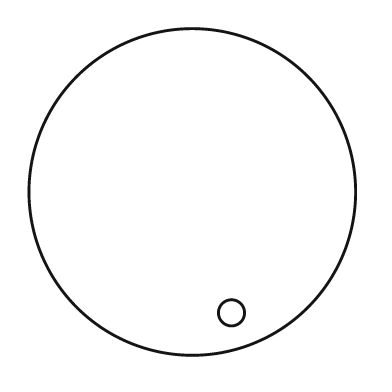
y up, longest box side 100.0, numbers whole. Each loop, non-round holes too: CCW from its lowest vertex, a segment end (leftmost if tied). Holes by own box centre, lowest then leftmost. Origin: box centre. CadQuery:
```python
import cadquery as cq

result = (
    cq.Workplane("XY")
    .moveTo(0.0, 0.0)
    .circle(50.0)
    .moveTo(12.0, -37.0)
    .circle(4.0)
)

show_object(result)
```